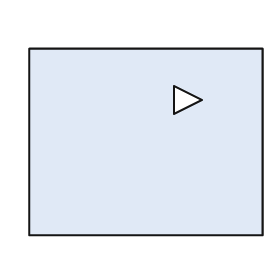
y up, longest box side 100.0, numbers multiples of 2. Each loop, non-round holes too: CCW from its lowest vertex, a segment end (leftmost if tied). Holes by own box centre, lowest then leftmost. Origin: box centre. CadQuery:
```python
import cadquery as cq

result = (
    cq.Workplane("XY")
    .moveTo(-50.0, -40.0)
    .lineTo(50.0, -40.0)
    .lineTo(50.0, 40.0)
    .lineTo(-50.0, 40.0)
    .close()
    .moveTo(12.0, 12.0)
    .lineTo(24.0, 18.0)
    .lineTo(12.0, 24.0)
    .close()
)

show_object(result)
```